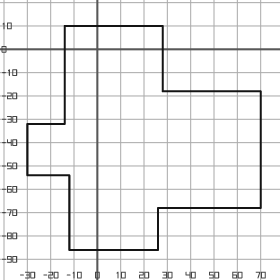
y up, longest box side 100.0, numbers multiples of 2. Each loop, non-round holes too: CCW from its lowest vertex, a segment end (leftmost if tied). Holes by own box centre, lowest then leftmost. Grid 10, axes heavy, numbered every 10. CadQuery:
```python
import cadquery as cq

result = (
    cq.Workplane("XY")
    .moveTo(-12.0, -86.0)
    .lineTo(26.0, -86.0)
    .lineTo(26.0, -68.0)
    .lineTo(70.0, -68.0)
    .lineTo(70.0, -18.0)
    .lineTo(28.0, -18.0)
    .lineTo(28.0, 10.0)
    .lineTo(-14.0, 10.0)
    .lineTo(-14.0, -32.0)
    .lineTo(-30.0, -32.0)
    .lineTo(-30.0, -54.0)
    .lineTo(-12.0, -54.0)
    .close()
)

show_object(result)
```